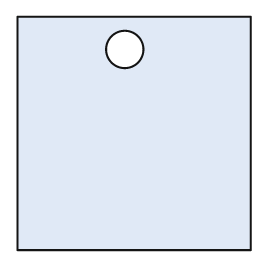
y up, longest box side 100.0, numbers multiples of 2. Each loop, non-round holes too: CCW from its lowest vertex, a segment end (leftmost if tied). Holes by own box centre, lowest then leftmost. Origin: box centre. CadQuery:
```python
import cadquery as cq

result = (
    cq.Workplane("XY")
    .moveTo(-50.0, -50.0)
    .lineTo(50.0, -50.0)
    .lineTo(50.0, 50.0)
    .lineTo(-50.0, 50.0)
    .close()
    .moveTo(-4.0, 36.0)
    .circle(8.0)
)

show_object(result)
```